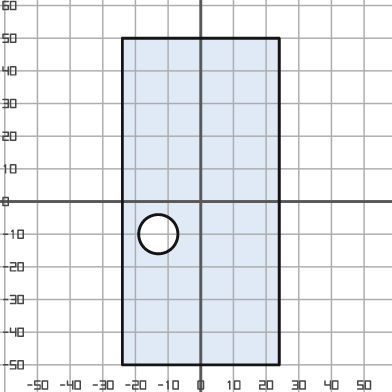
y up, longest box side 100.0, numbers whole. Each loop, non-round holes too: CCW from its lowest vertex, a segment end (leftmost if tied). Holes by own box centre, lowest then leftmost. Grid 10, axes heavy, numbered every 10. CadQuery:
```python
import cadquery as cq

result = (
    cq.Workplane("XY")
    .moveTo(-24.0, -50.0)
    .lineTo(24.0, -50.0)
    .lineTo(24.0, 50.0)
    .lineTo(-24.0, 50.0)
    .close()
    .moveTo(-13.0, -10.0)
    .circle(6.0)
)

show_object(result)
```